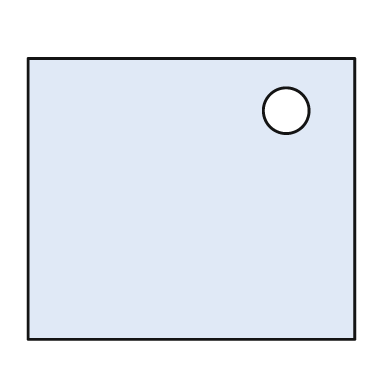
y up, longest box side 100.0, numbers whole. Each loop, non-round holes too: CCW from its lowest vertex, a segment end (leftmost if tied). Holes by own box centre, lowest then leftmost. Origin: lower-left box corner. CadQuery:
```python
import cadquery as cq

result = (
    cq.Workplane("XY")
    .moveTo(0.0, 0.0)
    .lineTo(100.0, 0.0)
    .lineTo(100.0, 86.0)
    .lineTo(0.0, 86.0)
    .close()
    .moveTo(79.0, 70.0)
    .circle(7.0)
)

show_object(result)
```